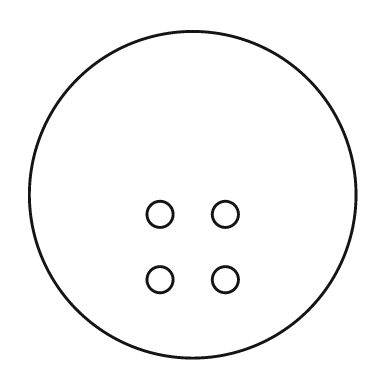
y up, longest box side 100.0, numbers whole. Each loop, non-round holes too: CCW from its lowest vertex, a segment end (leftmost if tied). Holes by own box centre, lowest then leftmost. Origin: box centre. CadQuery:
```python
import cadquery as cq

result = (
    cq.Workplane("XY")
    .moveTo(0.0, 0.0)
    .circle(50.0)
    .moveTo(-10.0, -26.0)
    .circle(4.0)
    .moveTo(10.0, -26.0)
    .circle(4.0)
    .moveTo(-10.0, -6.0)
    .circle(4.0)
    .moveTo(10.0, -6.0)
    .circle(4.0)
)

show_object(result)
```